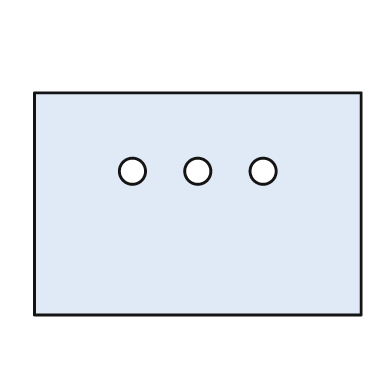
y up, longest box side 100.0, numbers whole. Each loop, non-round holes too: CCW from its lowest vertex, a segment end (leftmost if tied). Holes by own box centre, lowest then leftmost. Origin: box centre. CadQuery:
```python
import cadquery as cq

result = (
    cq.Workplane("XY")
    .moveTo(-50.0, -34.0)
    .lineTo(50.0, -34.0)
    .lineTo(50.0, 34.0)
    .lineTo(-50.0, 34.0)
    .close()
    .moveTo(-20.0, 10.0)
    .circle(4.0)
    .moveTo(0.0, 10.0)
    .circle(4.0)
    .moveTo(20.0, 10.0)
    .circle(4.0)
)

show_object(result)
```